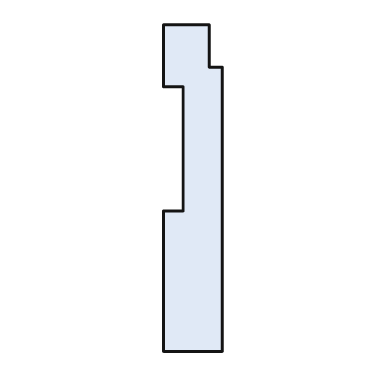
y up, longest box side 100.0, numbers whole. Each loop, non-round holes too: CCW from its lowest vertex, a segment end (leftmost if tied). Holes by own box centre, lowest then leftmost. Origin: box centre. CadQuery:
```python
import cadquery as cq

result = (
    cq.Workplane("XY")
    .moveTo(-9.0, -50.0)
    .lineTo(9.0, -50.0)
    .lineTo(9.0, 37.0)
    .lineTo(5.0, 37.0)
    .lineTo(5.0, 50.0)
    .lineTo(-9.0, 50.0)
    .lineTo(-9.0, 31.0)
    .lineTo(-3.0, 31.0)
    .lineTo(-3.0, -7.0)
    .lineTo(-9.0, -7.0)
    .close()
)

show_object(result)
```